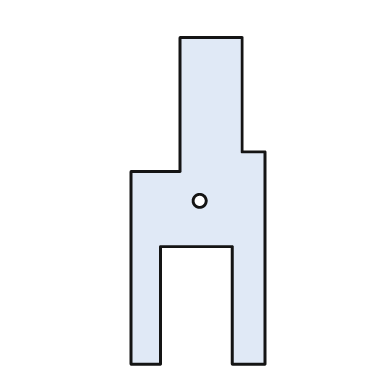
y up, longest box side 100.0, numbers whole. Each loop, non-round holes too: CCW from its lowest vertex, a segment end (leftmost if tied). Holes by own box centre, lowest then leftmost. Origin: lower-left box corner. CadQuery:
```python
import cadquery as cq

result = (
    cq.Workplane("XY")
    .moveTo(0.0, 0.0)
    .lineTo(9.0, 0.0)
    .lineTo(9.0, 36.0)
    .lineTo(31.0, 36.0)
    .lineTo(31.0, 0.0)
    .lineTo(41.0, 0.0)
    .lineTo(41.0, 65.0)
    .lineTo(34.0, 65.0)
    .lineTo(34.0, 100.0)
    .lineTo(15.0, 100.0)
    .lineTo(15.0, 59.0)
    .lineTo(0.0, 59.0)
    .close()
    .moveTo(21.0, 50.0)
    .circle(2.0)
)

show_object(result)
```